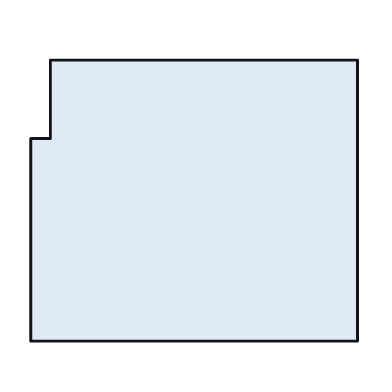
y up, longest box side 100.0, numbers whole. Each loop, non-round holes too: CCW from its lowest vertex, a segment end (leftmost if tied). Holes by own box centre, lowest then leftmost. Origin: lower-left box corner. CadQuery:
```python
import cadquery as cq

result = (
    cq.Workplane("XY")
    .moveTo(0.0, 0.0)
    .lineTo(100.0, 0.0)
    .lineTo(100.0, 86.0)
    .lineTo(6.0, 86.0)
    .lineTo(6.0, 62.0)
    .lineTo(0.0, 62.0)
    .close()
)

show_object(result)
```